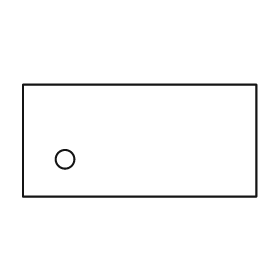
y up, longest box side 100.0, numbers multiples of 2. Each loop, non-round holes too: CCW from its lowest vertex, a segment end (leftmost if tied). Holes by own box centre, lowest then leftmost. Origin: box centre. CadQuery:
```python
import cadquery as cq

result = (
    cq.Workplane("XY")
    .moveTo(-50.0, -24.0)
    .lineTo(50.0, -24.0)
    .lineTo(50.0, 24.0)
    .lineTo(-50.0, 24.0)
    .close()
    .moveTo(-32.0, -8.0)
    .circle(4.0)
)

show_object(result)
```